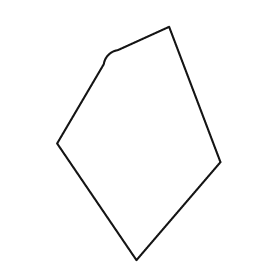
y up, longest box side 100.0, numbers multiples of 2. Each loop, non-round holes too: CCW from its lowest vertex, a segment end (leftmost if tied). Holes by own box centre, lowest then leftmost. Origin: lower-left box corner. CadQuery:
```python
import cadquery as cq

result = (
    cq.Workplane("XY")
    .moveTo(34.0, 0.0)
    .lineTo(70.0, 42.0)
    .lineTo(48.0, 100.0)
    .lineTo(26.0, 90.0)
    .threePointArc((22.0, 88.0), (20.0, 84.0))
    .lineTo(0.0, 50.0)
    .close()
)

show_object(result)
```